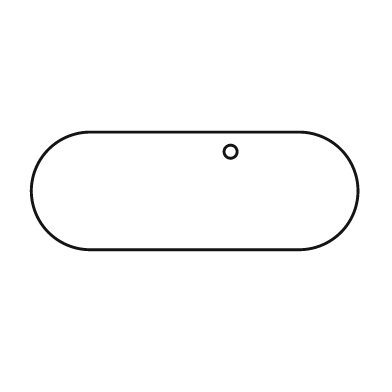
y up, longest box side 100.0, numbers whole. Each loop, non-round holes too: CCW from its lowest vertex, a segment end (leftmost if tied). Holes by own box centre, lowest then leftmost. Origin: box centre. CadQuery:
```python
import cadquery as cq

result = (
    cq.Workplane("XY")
    .moveTo(-32.0, -18.0)
    .lineTo(32.0, -18.0)
    .threePointArc((50.0, 0.0), (32.0, 18.0))
    .lineTo(-32.0, 18.0)
    .threePointArc((-50.0, 0.0), (-32.0, -18.0))
    .close()
    .moveTo(11.0, 12.0)
    .circle(2.0)
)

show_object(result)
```